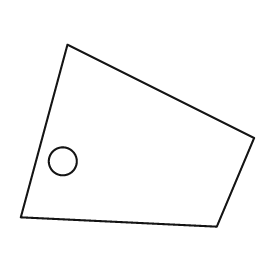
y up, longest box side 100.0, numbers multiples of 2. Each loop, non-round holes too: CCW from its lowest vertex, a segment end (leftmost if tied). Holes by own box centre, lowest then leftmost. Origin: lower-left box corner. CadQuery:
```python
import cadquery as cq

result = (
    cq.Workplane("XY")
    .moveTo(84.0, 0.0)
    .lineTo(100.0, 38.0)
    .lineTo(20.0, 78.0)
    .lineTo(0.0, 4.0)
    .close()
    .moveTo(18.0, 28.0)
    .circle(6.0)
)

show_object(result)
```